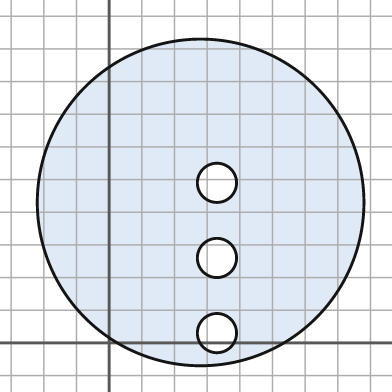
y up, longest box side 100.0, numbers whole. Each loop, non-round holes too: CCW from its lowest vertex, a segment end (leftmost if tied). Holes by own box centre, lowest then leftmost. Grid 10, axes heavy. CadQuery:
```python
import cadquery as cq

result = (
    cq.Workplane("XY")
    .moveTo(28.0, 43.0)
    .circle(50.0)
    .moveTo(33.0, 3.0)
    .circle(6.0)
    .moveTo(33.0, 26.0)
    .circle(6.0)
    .moveTo(33.0, 49.0)
    .circle(6.0)
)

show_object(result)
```